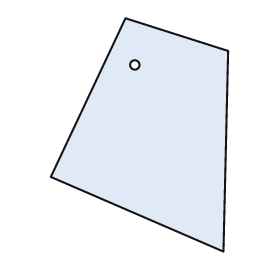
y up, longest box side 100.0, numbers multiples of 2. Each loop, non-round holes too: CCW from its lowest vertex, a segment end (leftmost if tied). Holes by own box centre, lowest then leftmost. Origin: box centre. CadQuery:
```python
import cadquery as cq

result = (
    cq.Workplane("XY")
    .moveTo(36.0, -50.0)
    .lineTo(38.0, 36.0)
    .lineTo(-6.0, 50.0)
    .lineTo(-38.0, -18.0)
    .close()
    .moveTo(-2.0, 30.0)
    .circle(2.0)
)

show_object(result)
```